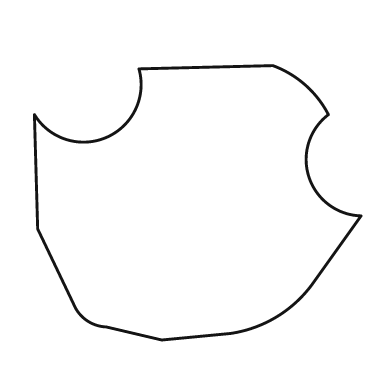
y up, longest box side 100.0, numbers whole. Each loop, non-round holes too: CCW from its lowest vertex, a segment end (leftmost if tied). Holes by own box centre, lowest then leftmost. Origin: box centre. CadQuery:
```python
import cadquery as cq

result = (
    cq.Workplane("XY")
    .moveTo(-11.0, -42.0)
    .lineTo(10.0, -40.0)
    .threePointArc((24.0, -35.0), (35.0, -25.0))
    .lineTo(50.0, -4.0)
    .threePointArc((34.0, 8.0), (40.0, 27.0))
    .threePointArc((33.0, 36.0), (23.0, 42.0))
    .lineTo(-18.0, 41.0)
    .threePointArc((-28.0, 20.0), (-50.0, 27.0))
    .lineTo(-49.0, -8.0)
    .lineTo(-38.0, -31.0)
    .threePointArc((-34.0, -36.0), (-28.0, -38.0))
    .close()
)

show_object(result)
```